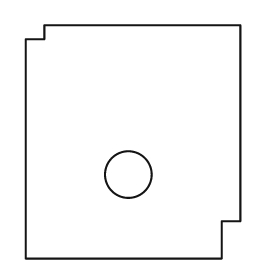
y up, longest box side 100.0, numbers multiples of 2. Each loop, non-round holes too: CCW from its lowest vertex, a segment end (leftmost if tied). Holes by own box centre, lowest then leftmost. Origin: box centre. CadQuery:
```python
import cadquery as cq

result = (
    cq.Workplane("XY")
    .moveTo(-46.0, -50.0)
    .lineTo(38.0, -50.0)
    .lineTo(38.0, -34.0)
    .lineTo(46.0, -34.0)
    .lineTo(46.0, 50.0)
    .lineTo(-38.0, 50.0)
    .lineTo(-38.0, 44.0)
    .lineTo(-46.0, 44.0)
    .close()
    .moveTo(-2.0, -14.0)
    .circle(10.0)
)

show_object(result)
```